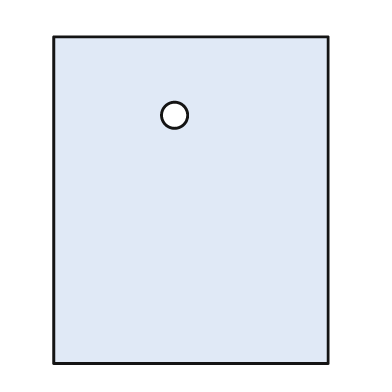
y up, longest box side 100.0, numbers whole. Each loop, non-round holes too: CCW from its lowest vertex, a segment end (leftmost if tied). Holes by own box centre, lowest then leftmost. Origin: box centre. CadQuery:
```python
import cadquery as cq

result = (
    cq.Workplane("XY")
    .moveTo(-42.0, -50.0)
    .lineTo(42.0, -50.0)
    .lineTo(42.0, 50.0)
    .lineTo(-42.0, 50.0)
    .close()
    .moveTo(-5.0, 26.0)
    .circle(4.0)
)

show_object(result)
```